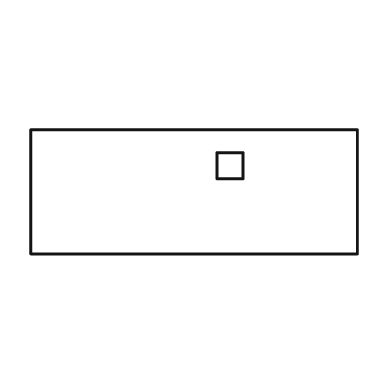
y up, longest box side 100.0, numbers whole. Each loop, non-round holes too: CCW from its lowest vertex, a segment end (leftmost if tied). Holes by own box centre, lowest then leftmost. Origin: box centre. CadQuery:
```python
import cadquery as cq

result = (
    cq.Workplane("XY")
    .moveTo(-50.0, -19.0)
    .lineTo(50.0, -19.0)
    .lineTo(50.0, 19.0)
    .lineTo(-50.0, 19.0)
    .close()
    .moveTo(7.0, 4.0)
    .lineTo(15.0, 4.0)
    .lineTo(15.0, 12.0)
    .lineTo(7.0, 12.0)
    .close()
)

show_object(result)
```